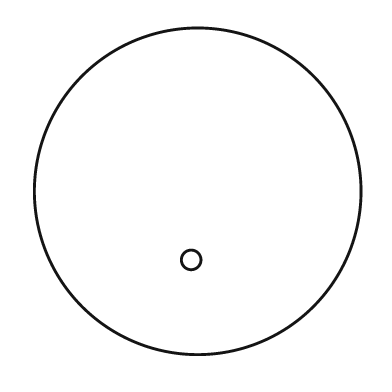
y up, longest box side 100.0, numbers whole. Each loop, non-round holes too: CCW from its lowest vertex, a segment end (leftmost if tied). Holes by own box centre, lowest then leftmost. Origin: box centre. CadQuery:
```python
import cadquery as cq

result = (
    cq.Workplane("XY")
    .moveTo(0.0, 0.0)
    .circle(50.0)
    .moveTo(-2.0, -21.0)
    .circle(3.0)
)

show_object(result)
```